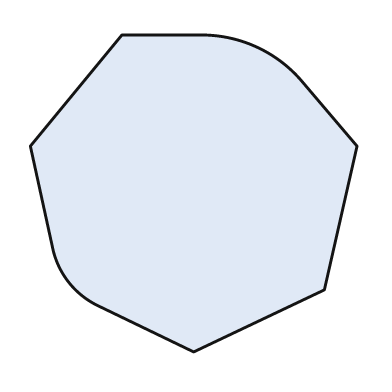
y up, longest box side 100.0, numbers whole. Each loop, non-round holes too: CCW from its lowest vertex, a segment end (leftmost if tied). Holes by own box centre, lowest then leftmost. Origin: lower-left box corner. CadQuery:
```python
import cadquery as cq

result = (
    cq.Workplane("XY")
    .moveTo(50.0, 0.0)
    .lineTo(90.0, 19.0)
    .lineTo(100.0, 63.0)
    .lineTo(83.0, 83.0)
    .threePointArc((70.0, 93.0), (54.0, 97.0))
    .lineTo(28.0, 97.0)
    .lineTo(0.0, 63.0)
    .lineTo(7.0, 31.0)
    .threePointArc((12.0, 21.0), (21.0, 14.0))
    .close()
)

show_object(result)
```